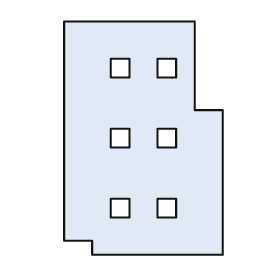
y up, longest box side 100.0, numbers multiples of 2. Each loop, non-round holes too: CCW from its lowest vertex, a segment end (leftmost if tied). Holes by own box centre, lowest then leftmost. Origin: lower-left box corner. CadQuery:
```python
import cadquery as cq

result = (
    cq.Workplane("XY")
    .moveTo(12.0, 0.0)
    .lineTo(68.0, 0.0)
    .lineTo(68.0, 62.0)
    .lineTo(56.0, 62.0)
    .lineTo(56.0, 100.0)
    .lineTo(0.0, 100.0)
    .lineTo(0.0, 6.0)
    .lineTo(12.0, 6.0)
    .close()
    .moveTo(20.0, 16.0)
    .lineTo(28.0, 16.0)
    .lineTo(28.0, 24.0)
    .lineTo(20.0, 24.0)
    .close()
    .moveTo(40.0, 16.0)
    .lineTo(48.0, 16.0)
    .lineTo(48.0, 24.0)
    .lineTo(40.0, 24.0)
    .close()
    .moveTo(20.0, 46.0)
    .lineTo(28.0, 46.0)
    .lineTo(28.0, 54.0)
    .lineTo(20.0, 54.0)
    .close()
    .moveTo(40.0, 46.0)
    .lineTo(48.0, 46.0)
    .lineTo(48.0, 54.0)
    .lineTo(40.0, 54.0)
    .close()
    .moveTo(20.0, 76.0)
    .lineTo(28.0, 76.0)
    .lineTo(28.0, 84.0)
    .lineTo(20.0, 84.0)
    .close()
    .moveTo(40.0, 76.0)
    .lineTo(48.0, 76.0)
    .lineTo(48.0, 84.0)
    .lineTo(40.0, 84.0)
    .close()
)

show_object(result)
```